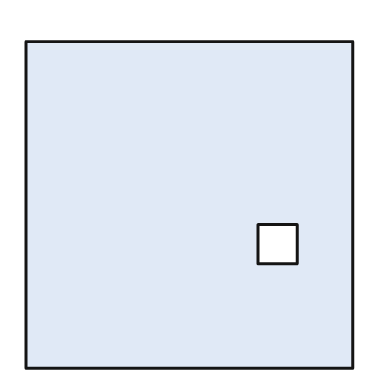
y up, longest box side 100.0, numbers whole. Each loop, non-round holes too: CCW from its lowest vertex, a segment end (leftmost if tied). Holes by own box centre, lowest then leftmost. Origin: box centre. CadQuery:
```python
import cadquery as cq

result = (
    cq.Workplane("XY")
    .moveTo(-50.0, -50.0)
    .lineTo(50.0, -50.0)
    .lineTo(50.0, 50.0)
    .lineTo(-50.0, 50.0)
    .close()
    .moveTo(21.0, -18.0)
    .lineTo(33.0, -18.0)
    .lineTo(33.0, -6.0)
    .lineTo(21.0, -6.0)
    .close()
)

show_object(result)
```